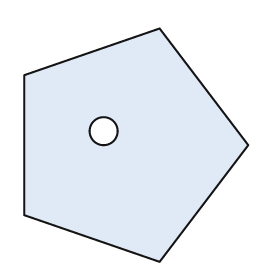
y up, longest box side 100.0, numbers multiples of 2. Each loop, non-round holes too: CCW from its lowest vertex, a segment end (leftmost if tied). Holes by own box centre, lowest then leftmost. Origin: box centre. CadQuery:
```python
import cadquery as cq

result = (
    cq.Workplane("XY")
    .moveTo(10.0, -50.0)
    .lineTo(48.0, 0.0)
    .lineTo(10.0, 50.0)
    .lineTo(-48.0, 30.0)
    .lineTo(-48.0, -30.0)
    .close()
    .moveTo(-14.0, 6.0)
    .circle(6.0)
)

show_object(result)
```